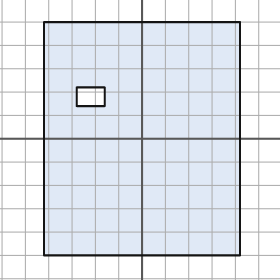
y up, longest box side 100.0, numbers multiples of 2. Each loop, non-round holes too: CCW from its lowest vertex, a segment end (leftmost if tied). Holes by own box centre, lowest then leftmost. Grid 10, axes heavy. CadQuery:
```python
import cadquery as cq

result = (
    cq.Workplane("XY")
    .moveTo(-42.0, -50.0)
    .lineTo(42.0, -50.0)
    .lineTo(42.0, 50.0)
    .lineTo(-42.0, 50.0)
    .close()
    .moveTo(-28.0, 14.0)
    .lineTo(-16.0, 14.0)
    .lineTo(-16.0, 22.0)
    .lineTo(-28.0, 22.0)
    .close()
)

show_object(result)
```